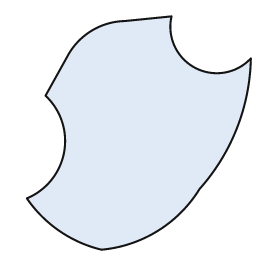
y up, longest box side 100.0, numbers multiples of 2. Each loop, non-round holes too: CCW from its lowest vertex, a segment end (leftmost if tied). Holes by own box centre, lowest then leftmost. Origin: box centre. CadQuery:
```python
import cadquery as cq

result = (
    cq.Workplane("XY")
    .moveTo(-16.0, -50.0)
    .threePointArc((8.0, -42.0), (26.0, -24.0))
    .threePointArc((42.0, 2.0), (48.0, 32.0))
    .threePointArc((24.0, 28.0), (14.0, 50.0))
    .lineTo(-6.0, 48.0)
    .threePointArc((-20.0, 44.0), (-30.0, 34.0))
    .lineTo(-40.0, 16.0)
    .threePointArc((-32.0, -8.0), (-48.0, -28.0))
    .threePointArc((-34.0, -42.0), (-16.0, -50.0))
    .close()
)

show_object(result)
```